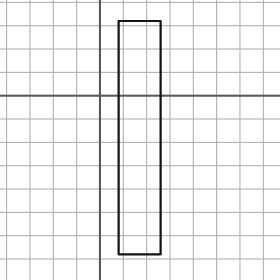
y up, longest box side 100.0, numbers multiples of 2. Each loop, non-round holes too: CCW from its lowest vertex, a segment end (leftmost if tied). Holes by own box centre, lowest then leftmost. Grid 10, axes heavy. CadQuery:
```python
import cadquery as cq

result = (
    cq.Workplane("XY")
    .moveTo(8.0, -68.0)
    .lineTo(26.0, -68.0)
    .lineTo(26.0, 32.0)
    .lineTo(8.0, 32.0)
    .close()
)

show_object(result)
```